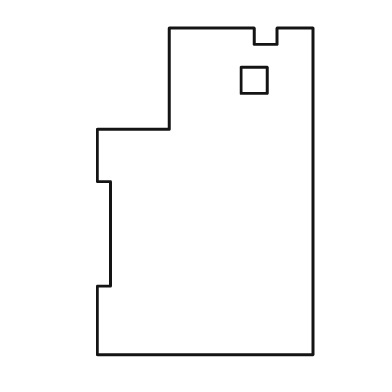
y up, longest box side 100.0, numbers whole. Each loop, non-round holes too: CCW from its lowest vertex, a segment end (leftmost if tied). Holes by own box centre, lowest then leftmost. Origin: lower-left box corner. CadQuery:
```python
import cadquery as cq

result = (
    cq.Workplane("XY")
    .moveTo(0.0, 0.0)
    .lineTo(66.0, 0.0)
    .lineTo(66.0, 100.0)
    .lineTo(55.0, 100.0)
    .lineTo(55.0, 95.0)
    .lineTo(48.0, 95.0)
    .lineTo(48.0, 100.0)
    .lineTo(22.0, 100.0)
    .lineTo(22.0, 69.0)
    .lineTo(0.0, 69.0)
    .lineTo(0.0, 53.0)
    .lineTo(4.0, 53.0)
    .lineTo(4.0, 21.0)
    .lineTo(0.0, 21.0)
    .close()
    .moveTo(44.0, 80.0)
    .lineTo(52.0, 80.0)
    .lineTo(52.0, 88.0)
    .lineTo(44.0, 88.0)
    .close()
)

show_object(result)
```